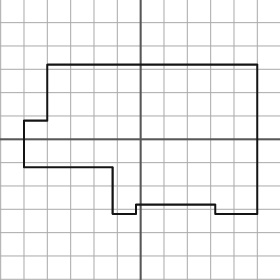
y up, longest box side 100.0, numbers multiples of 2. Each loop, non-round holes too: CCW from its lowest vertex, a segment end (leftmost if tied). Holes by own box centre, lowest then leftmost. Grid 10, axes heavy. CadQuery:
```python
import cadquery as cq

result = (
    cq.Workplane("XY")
    .moveTo(-12.0, -32.0)
    .lineTo(-2.0, -32.0)
    .lineTo(-2.0, -28.0)
    .lineTo(32.0, -28.0)
    .lineTo(32.0, -32.0)
    .lineTo(50.0, -32.0)
    .lineTo(50.0, 32.0)
    .lineTo(-40.0, 32.0)
    .lineTo(-40.0, 8.0)
    .lineTo(-50.0, 8.0)
    .lineTo(-50.0, -12.0)
    .lineTo(-12.0, -12.0)
    .close()
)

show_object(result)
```